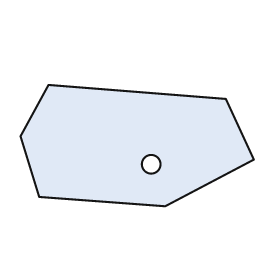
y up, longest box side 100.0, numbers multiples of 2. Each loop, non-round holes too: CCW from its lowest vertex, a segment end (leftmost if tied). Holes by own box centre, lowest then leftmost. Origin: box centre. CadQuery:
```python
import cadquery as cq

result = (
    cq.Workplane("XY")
    .moveTo(12.0, -26.0)
    .lineTo(50.0, -6.0)
    .lineTo(38.0, 20.0)
    .lineTo(-38.0, 26.0)
    .lineTo(-50.0, 4.0)
    .lineTo(-42.0, -22.0)
    .close()
    .moveTo(6.0, -8.0)
    .circle(4.0)
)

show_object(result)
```